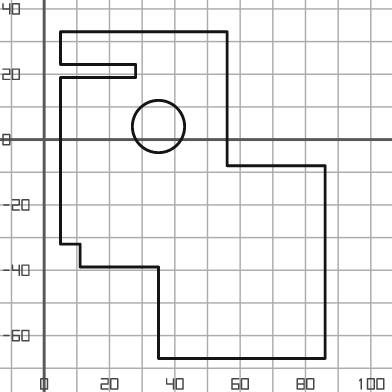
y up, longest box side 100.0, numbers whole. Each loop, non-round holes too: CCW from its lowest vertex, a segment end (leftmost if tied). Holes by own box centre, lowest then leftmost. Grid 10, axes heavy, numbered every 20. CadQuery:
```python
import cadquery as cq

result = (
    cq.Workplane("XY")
    .moveTo(35.0, -67.0)
    .lineTo(86.0, -67.0)
    .lineTo(86.0, -8.0)
    .lineTo(56.0, -8.0)
    .lineTo(56.0, 33.0)
    .lineTo(5.0, 33.0)
    .lineTo(5.0, 23.0)
    .lineTo(28.0, 23.0)
    .lineTo(28.0, 19.0)
    .lineTo(5.0, 19.0)
    .lineTo(5.0, -32.0)
    .lineTo(11.0, -32.0)
    .lineTo(11.0, -39.0)
    .lineTo(35.0, -39.0)
    .close()
    .moveTo(35.0, 4.0)
    .circle(8.0)
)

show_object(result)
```